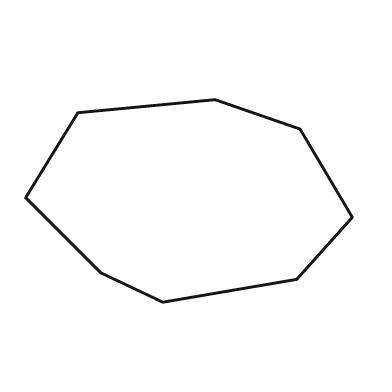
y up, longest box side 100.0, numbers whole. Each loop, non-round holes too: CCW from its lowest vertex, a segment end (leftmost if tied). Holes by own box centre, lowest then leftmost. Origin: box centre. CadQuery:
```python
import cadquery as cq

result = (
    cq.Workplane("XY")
    .moveTo(-8.0, -31.0)
    .lineTo(33.0, -24.0)
    .lineTo(50.0, -5.0)
    .lineTo(34.0, 22.0)
    .lineTo(8.0, 31.0)
    .lineTo(-34.0, 27.0)
    .lineTo(-50.0, 1.0)
    .lineTo(-27.0, -22.0)
    .close()
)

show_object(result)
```